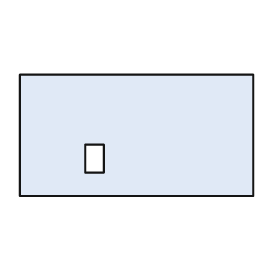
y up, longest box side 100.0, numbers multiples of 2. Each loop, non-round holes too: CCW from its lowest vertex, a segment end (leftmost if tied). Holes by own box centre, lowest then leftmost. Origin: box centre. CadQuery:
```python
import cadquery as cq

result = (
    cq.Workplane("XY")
    .moveTo(-50.0, -26.0)
    .lineTo(50.0, -26.0)
    .lineTo(50.0, 26.0)
    .lineTo(-50.0, 26.0)
    .close()
    .moveTo(-22.0, -16.0)
    .lineTo(-14.0, -16.0)
    .lineTo(-14.0, -4.0)
    .lineTo(-22.0, -4.0)
    .close()
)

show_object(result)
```